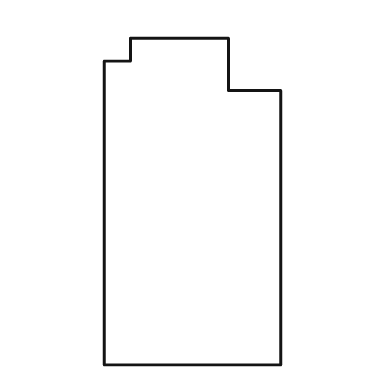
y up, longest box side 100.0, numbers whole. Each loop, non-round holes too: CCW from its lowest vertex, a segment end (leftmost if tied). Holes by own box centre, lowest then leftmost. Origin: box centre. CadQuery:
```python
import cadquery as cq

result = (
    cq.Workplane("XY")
    .moveTo(-27.0, -50.0)
    .lineTo(27.0, -50.0)
    .lineTo(27.0, 34.0)
    .lineTo(11.0, 34.0)
    .lineTo(11.0, 50.0)
    .lineTo(-19.0, 50.0)
    .lineTo(-19.0, 43.0)
    .lineTo(-27.0, 43.0)
    .close()
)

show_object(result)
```